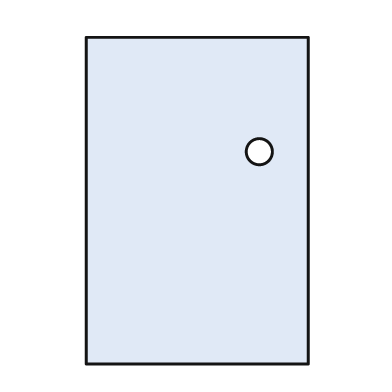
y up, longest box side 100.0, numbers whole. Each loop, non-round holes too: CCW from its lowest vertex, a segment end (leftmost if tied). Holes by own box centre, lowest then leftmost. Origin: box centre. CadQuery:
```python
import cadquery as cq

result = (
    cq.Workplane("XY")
    .moveTo(-34.0, -50.0)
    .lineTo(34.0, -50.0)
    .lineTo(34.0, 50.0)
    .lineTo(-34.0, 50.0)
    .close()
    .moveTo(19.0, 15.0)
    .circle(4.0)
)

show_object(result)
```